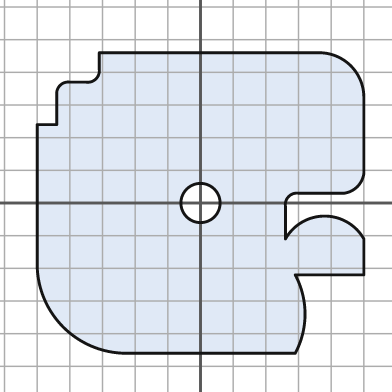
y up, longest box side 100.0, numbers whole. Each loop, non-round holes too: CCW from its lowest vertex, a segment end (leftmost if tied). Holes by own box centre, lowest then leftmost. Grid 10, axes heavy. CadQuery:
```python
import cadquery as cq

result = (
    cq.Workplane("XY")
    .moveTo(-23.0, -46.0)
    .lineTo(29.0, -46.0)
    .threePointArc((32.0, -34.0), (29.0, -22.0))
    .lineTo(50.0, -22.0)
    .lineTo(50.0, -11.0)
    .threePointArc((38.0, -4.0), (26.0, -11.0))
    .lineTo(26.0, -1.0)
    .threePointArc((27.0, 2.0), (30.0, 3.0))
    .lineTo(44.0, 3.0)
    .threePointArc((48.0, 5.0), (50.0, 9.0))
    .lineTo(50.0, 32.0)
    .threePointArc((46.0, 42.0), (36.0, 46.0))
    .lineTo(-31.0, 46.0)
    .lineTo(-31.0, 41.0)
    .threePointArc((-32.0, 38.0), (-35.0, 37.0))
    .lineTo(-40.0, 37.0)
    .threePointArc((-43.0, 36.0), (-44.0, 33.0))
    .lineTo(-44.0, 24.0)
    .lineTo(-50.0, 24.0)
    .lineTo(-50.0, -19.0)
    .threePointArc((-42.0, -38.0), (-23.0, -46.0))
    .close()
    .moveTo(0.0, 0.0)
    .circle(6.0)
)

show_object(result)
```